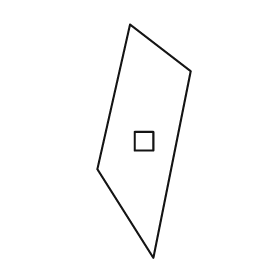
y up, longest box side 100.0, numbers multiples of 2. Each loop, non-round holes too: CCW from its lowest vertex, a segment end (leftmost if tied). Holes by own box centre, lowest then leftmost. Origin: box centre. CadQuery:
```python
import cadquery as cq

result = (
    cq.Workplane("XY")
    .moveTo(4.0, -50.0)
    .lineTo(20.0, 30.0)
    .lineTo(-6.0, 50.0)
    .lineTo(-20.0, -12.0)
    .close()
    .moveTo(-4.0, -4.0)
    .lineTo(4.0, -4.0)
    .lineTo(4.0, 4.0)
    .lineTo(-4.0, 4.0)
    .close()
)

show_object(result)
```